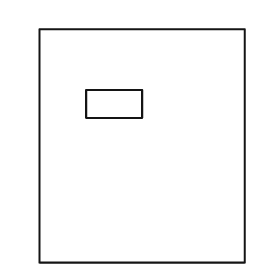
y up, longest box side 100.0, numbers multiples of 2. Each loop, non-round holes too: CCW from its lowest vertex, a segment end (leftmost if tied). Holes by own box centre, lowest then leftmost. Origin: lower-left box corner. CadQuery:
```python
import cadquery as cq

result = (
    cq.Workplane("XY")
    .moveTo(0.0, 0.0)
    .lineTo(88.0, 0.0)
    .lineTo(88.0, 100.0)
    .lineTo(0.0, 100.0)
    .close()
    .moveTo(20.0, 62.0)
    .lineTo(44.0, 62.0)
    .lineTo(44.0, 74.0)
    .lineTo(20.0, 74.0)
    .close()
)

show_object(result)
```